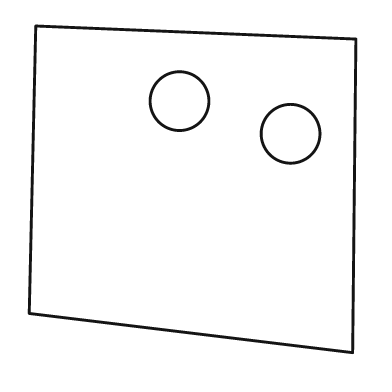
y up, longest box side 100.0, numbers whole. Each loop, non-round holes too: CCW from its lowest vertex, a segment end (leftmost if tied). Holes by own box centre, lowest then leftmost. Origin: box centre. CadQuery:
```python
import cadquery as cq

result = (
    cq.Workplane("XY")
    .moveTo(49.0, -50.0)
    .lineTo(50.0, 46.0)
    .lineTo(-48.0, 50.0)
    .lineTo(-50.0, -38.0)
    .close()
    .moveTo(30.0, 17.0)
    .circle(9.0)
    .moveTo(-4.0, 27.0)
    .circle(9.0)
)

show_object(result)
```